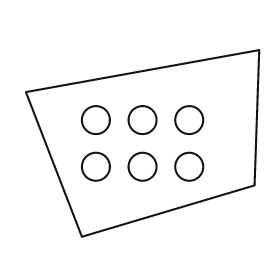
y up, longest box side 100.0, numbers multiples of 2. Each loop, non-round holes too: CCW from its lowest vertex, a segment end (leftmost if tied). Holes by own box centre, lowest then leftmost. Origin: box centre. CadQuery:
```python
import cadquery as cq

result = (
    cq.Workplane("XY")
    .moveTo(-26.0, -40.0)
    .lineTo(48.0, -18.0)
    .lineTo(50.0, 40.0)
    .lineTo(-50.0, 22.0)
    .close()
    .moveTo(-20.0, -10.0)
    .circle(6.0)
    .moveTo(0.0, -10.0)
    .circle(6.0)
    .moveTo(20.0, -10.0)
    .circle(6.0)
    .moveTo(-20.0, 10.0)
    .circle(6.0)
    .moveTo(0.0, 10.0)
    .circle(6.0)
    .moveTo(20.0, 10.0)
    .circle(6.0)
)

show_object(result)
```